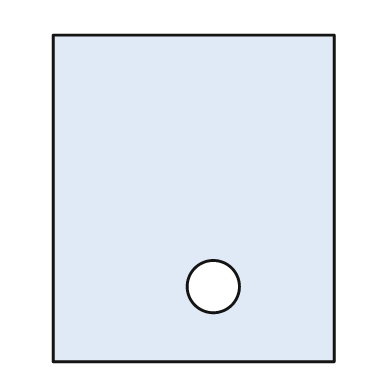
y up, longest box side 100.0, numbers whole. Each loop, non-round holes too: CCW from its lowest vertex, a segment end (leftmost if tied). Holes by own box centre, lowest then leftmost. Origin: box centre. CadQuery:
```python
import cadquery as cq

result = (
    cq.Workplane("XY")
    .moveTo(-43.0, -50.0)
    .lineTo(43.0, -50.0)
    .lineTo(43.0, 50.0)
    .lineTo(-43.0, 50.0)
    .close()
    .moveTo(6.0, -27.0)
    .circle(8.0)
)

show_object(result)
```